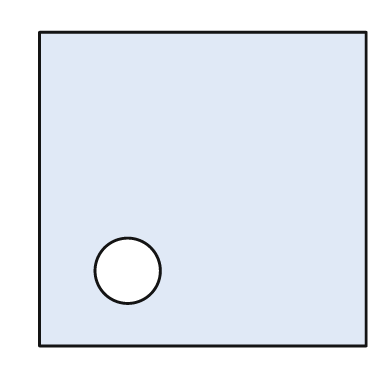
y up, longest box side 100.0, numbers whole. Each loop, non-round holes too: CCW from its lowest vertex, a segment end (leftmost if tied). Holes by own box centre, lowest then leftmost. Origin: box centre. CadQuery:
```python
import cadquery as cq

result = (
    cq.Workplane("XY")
    .moveTo(-50.0, -48.0)
    .lineTo(50.0, -48.0)
    .lineTo(50.0, 48.0)
    .lineTo(-50.0, 48.0)
    .close()
    .moveTo(-23.0, -25.0)
    .circle(10.0)
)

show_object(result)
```